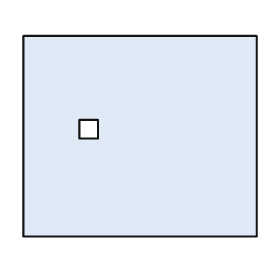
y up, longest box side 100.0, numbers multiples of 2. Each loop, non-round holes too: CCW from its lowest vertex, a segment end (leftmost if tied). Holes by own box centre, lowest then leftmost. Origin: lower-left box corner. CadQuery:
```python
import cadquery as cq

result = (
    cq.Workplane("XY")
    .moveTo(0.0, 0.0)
    .lineTo(100.0, 0.0)
    .lineTo(100.0, 86.0)
    .lineTo(0.0, 86.0)
    .close()
    .moveTo(24.0, 42.0)
    .lineTo(32.0, 42.0)
    .lineTo(32.0, 50.0)
    .lineTo(24.0, 50.0)
    .close()
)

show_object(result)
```